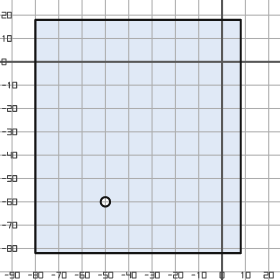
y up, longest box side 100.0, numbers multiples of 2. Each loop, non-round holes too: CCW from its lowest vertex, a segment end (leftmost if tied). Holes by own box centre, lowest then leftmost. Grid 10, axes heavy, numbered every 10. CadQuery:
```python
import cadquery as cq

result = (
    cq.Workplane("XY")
    .moveTo(-80.0, -82.0)
    .lineTo(8.0, -82.0)
    .lineTo(8.0, 18.0)
    .lineTo(-80.0, 18.0)
    .close()
    .moveTo(-50.0, -60.0)
    .circle(2.0)
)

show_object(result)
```